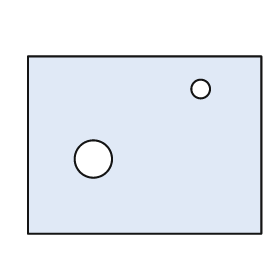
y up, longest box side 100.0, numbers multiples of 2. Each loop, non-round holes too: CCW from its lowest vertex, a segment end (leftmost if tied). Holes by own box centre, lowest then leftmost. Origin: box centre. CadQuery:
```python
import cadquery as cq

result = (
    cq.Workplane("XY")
    .moveTo(-50.0, -38.0)
    .lineTo(50.0, -38.0)
    .lineTo(50.0, 38.0)
    .lineTo(-50.0, 38.0)
    .close()
    .moveTo(-22.0, -6.0)
    .circle(8.0)
    .moveTo(24.0, 24.0)
    .circle(4.0)
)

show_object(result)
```